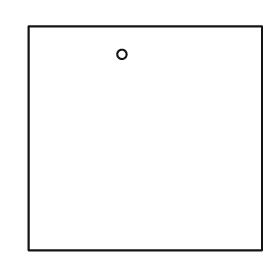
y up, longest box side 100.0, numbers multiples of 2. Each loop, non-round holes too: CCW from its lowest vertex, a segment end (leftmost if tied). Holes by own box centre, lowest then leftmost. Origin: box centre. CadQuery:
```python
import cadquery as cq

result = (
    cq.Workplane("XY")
    .moveTo(-50.0, -48.0)
    .lineTo(50.0, -48.0)
    .lineTo(50.0, 48.0)
    .lineTo(-50.0, 48.0)
    .close()
    .moveTo(-10.0, 36.0)
    .circle(2.0)
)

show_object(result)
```